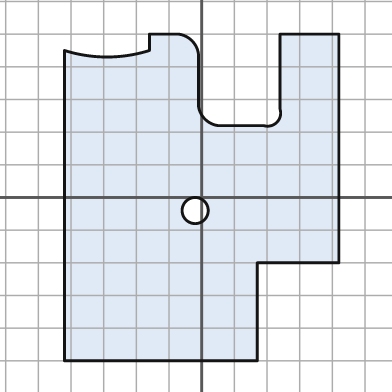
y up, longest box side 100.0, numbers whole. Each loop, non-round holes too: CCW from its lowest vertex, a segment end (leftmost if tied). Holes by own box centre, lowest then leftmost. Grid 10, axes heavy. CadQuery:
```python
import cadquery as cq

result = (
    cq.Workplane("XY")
    .moveTo(-42.0, -50.0)
    .lineTo(17.0, -50.0)
    .lineTo(17.0, -20.0)
    .lineTo(42.0, -20.0)
    .lineTo(42.0, 50.0)
    .lineTo(24.0, 50.0)
    .lineTo(24.0, 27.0)
    .threePointArc((23.0, 23.0), (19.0, 22.0))
    .lineTo(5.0, 22.0)
    .threePointArc((1.0, 24.0), (-1.0, 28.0))
    .lineTo(-1.0, 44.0)
    .threePointArc((-3.0, 48.0), (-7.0, 50.0))
    .lineTo(-16.0, 50.0)
    .lineTo(-16.0, 45.0)
    .threePointArc((-29.0, 43.0), (-42.0, 45.0))
    .close()
    .moveTo(-2.0, -4.0)
    .circle(4.0)
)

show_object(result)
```